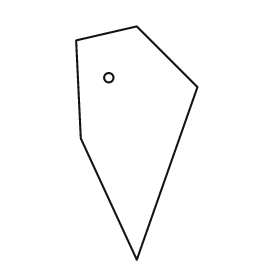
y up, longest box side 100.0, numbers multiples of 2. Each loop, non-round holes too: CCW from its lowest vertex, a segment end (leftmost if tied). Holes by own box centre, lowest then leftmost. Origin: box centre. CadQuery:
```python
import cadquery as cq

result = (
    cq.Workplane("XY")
    .moveTo(0.0, -50.0)
    .lineTo(26.0, 24.0)
    .lineTo(0.0, 50.0)
    .lineTo(-26.0, 44.0)
    .lineTo(-24.0, 2.0)
    .close()
    .moveTo(-12.0, 28.0)
    .circle(2.0)
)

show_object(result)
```